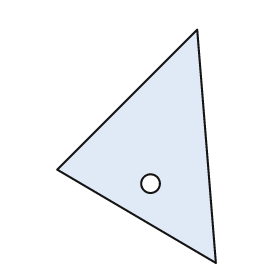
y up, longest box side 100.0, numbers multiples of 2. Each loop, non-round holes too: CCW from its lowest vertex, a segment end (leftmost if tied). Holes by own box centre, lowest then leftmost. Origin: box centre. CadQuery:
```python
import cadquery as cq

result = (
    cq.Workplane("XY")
    .moveTo(34.0, -50.0)
    .lineTo(26.0, 50.0)
    .lineTo(-34.0, -10.0)
    .close()
    .moveTo(6.0, -16.0)
    .circle(4.0)
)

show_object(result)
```